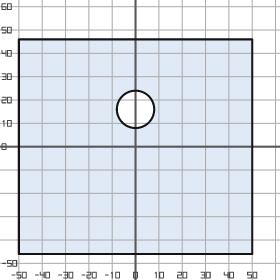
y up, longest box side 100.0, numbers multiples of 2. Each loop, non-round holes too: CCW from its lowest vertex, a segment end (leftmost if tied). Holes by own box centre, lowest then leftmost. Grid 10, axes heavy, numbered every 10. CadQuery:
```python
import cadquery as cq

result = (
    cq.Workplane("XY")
    .moveTo(-50.0, -46.0)
    .lineTo(50.0, -46.0)
    .lineTo(50.0, 46.0)
    .lineTo(-50.0, 46.0)
    .close()
    .moveTo(0.0, 16.0)
    .circle(8.0)
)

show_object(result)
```